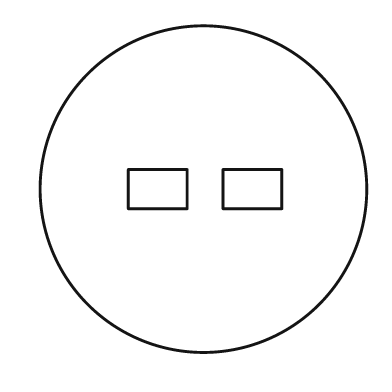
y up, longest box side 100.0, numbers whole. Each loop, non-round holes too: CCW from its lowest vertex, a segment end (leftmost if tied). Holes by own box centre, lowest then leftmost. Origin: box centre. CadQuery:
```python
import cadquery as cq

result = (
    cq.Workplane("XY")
    .moveTo(0.0, 0.0)
    .circle(50.0)
    .moveTo(-23.0, -6.0)
    .lineTo(-5.0, -6.0)
    .lineTo(-5.0, 6.0)
    .lineTo(-23.0, 6.0)
    .close()
    .moveTo(6.0, -6.0)
    .lineTo(24.0, -6.0)
    .lineTo(24.0, 6.0)
    .lineTo(6.0, 6.0)
    .close()
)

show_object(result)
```